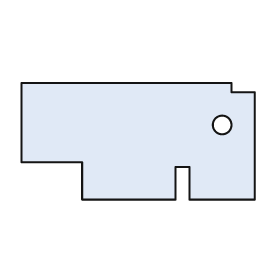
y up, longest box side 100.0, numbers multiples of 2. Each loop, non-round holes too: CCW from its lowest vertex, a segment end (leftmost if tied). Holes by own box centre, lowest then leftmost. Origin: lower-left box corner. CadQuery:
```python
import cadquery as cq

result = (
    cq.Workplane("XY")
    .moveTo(26.0, 0.0)
    .lineTo(66.0, 0.0)
    .lineTo(66.0, 14.0)
    .lineTo(72.0, 14.0)
    .lineTo(72.0, 0.0)
    .lineTo(100.0, 0.0)
    .lineTo(100.0, 46.0)
    .lineTo(90.0, 46.0)
    .lineTo(90.0, 50.0)
    .lineTo(0.0, 50.0)
    .lineTo(0.0, 16.0)
    .lineTo(26.0, 16.0)
    .close()
    .moveTo(86.0, 32.0)
    .circle(4.0)
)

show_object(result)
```